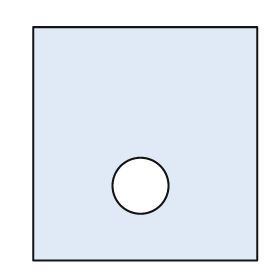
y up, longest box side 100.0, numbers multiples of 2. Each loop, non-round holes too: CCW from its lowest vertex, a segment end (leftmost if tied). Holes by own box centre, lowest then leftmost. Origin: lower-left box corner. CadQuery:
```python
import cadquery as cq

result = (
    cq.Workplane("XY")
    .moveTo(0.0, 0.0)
    .lineTo(96.0, 0.0)
    .lineTo(96.0, 100.0)
    .lineTo(0.0, 100.0)
    .close()
    .moveTo(46.0, 32.0)
    .circle(12.0)
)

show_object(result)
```